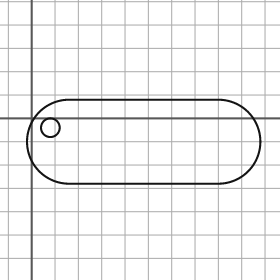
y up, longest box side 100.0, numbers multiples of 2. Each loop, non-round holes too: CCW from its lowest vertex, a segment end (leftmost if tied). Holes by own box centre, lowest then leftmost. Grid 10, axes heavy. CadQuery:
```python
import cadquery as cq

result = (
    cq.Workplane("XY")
    .moveTo(16.0, -28.0)
    .lineTo(80.0, -28.0)
    .threePointArc((98.0, -10.0), (80.0, 8.0))
    .lineTo(16.0, 8.0)
    .threePointArc((-2.0, -10.0), (16.0, -28.0))
    .close()
    .moveTo(8.0, -4.0)
    .circle(4.0)
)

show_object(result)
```